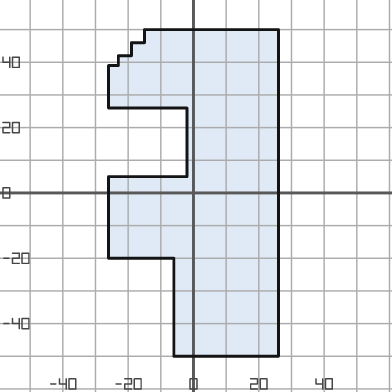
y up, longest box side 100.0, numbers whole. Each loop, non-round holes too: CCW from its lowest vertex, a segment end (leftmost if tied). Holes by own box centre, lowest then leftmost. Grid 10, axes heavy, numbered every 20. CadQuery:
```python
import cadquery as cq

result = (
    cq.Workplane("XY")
    .moveTo(-6.0, -50.0)
    .lineTo(26.0, -50.0)
    .lineTo(26.0, 50.0)
    .lineTo(-15.0, 50.0)
    .lineTo(-15.0, 46.0)
    .lineTo(-19.0, 46.0)
    .lineTo(-19.0, 42.0)
    .lineTo(-23.0, 42.0)
    .lineTo(-23.0, 39.0)
    .lineTo(-26.0, 39.0)
    .lineTo(-26.0, 26.0)
    .lineTo(-2.0, 26.0)
    .lineTo(-2.0, 5.0)
    .lineTo(-26.0, 5.0)
    .lineTo(-26.0, -20.0)
    .lineTo(-6.0, -20.0)
    .close()
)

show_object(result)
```